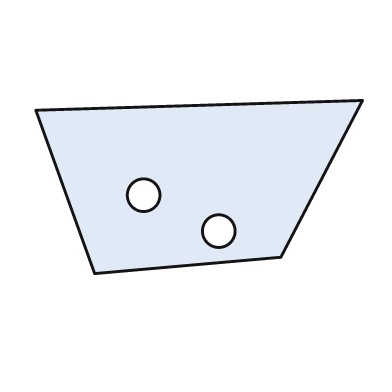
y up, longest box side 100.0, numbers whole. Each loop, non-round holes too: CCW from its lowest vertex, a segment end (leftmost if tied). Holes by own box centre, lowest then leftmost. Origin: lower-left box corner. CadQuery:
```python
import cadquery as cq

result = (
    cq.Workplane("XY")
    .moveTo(18.0, 0.0)
    .lineTo(75.0, 5.0)
    .lineTo(100.0, 53.0)
    .lineTo(0.0, 50.0)
    .close()
    .moveTo(56.0, 13.0)
    .circle(5.0)
    .moveTo(33.0, 24.0)
    .circle(5.0)
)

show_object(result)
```